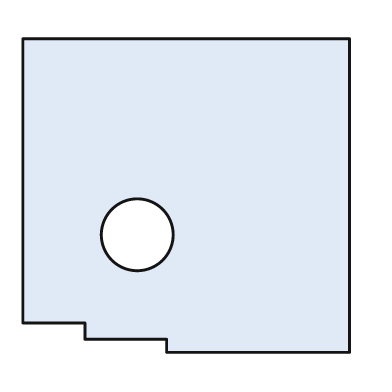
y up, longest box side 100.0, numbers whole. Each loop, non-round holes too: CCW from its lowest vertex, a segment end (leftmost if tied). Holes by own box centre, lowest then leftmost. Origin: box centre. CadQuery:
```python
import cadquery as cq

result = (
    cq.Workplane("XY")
    .moveTo(-6.0, -48.0)
    .lineTo(50.0, -48.0)
    .lineTo(50.0, 48.0)
    .lineTo(-50.0, 48.0)
    .lineTo(-50.0, -39.0)
    .lineTo(-31.0, -39.0)
    .lineTo(-31.0, -44.0)
    .lineTo(-6.0, -44.0)
    .close()
    .moveTo(-15.0, -12.0)
    .circle(11.0)
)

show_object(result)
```